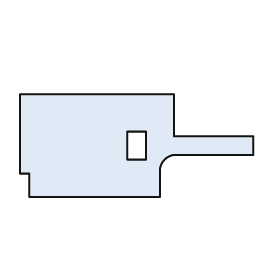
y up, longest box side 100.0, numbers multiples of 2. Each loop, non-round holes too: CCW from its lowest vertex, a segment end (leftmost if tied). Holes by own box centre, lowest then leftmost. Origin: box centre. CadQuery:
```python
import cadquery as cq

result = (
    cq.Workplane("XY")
    .moveTo(-46.0, -22.0)
    .lineTo(10.0, -22.0)
    .lineTo(10.0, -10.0)
    .threePointArc((12.0, -6.0), (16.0, -4.0))
    .lineTo(50.0, -4.0)
    .lineTo(50.0, 4.0)
    .lineTo(16.0, 4.0)
    .lineTo(16.0, 22.0)
    .lineTo(-50.0, 22.0)
    .lineTo(-50.0, -12.0)
    .lineTo(-46.0, -12.0)
    .close()
    .moveTo(-4.0, -6.0)
    .lineTo(4.0, -6.0)
    .lineTo(4.0, 6.0)
    .lineTo(-4.0, 6.0)
    .close()
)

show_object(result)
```